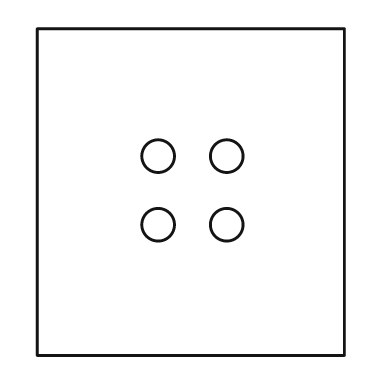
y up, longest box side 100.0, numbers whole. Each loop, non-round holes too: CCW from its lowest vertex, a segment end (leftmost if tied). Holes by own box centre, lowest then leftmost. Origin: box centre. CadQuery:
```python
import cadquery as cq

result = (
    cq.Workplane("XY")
    .moveTo(-47.0, -50.0)
    .lineTo(47.0, -50.0)
    .lineTo(47.0, 50.0)
    .lineTo(-47.0, 50.0)
    .close()
    .moveTo(-10.0, -10.0)
    .circle(5.0)
    .moveTo(11.0, -10.0)
    .circle(5.0)
    .moveTo(-10.0, 11.0)
    .circle(5.0)
    .moveTo(11.0, 11.0)
    .circle(5.0)
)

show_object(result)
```